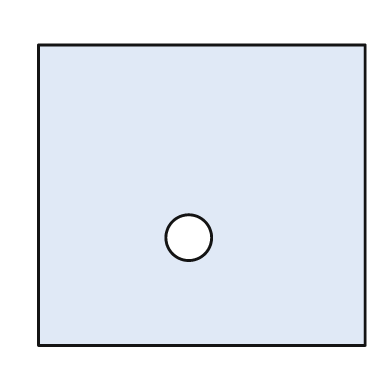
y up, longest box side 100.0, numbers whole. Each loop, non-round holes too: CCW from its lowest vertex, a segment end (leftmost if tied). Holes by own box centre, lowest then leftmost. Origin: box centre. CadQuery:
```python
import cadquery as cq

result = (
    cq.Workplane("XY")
    .moveTo(-50.0, -46.0)
    .lineTo(50.0, -46.0)
    .lineTo(50.0, 46.0)
    .lineTo(-50.0, 46.0)
    .close()
    .moveTo(-4.0, -13.0)
    .circle(7.0)
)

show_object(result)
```